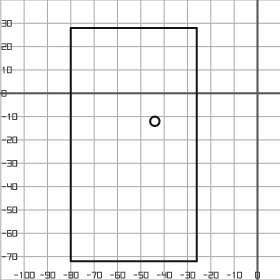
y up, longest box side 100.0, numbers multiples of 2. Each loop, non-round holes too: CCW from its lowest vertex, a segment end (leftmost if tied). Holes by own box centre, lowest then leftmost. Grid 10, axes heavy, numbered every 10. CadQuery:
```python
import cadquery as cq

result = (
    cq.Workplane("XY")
    .moveTo(-80.0, -72.0)
    .lineTo(-26.0, -72.0)
    .lineTo(-26.0, 28.0)
    .lineTo(-80.0, 28.0)
    .close()
    .moveTo(-44.0, -12.0)
    .circle(2.0)
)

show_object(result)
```